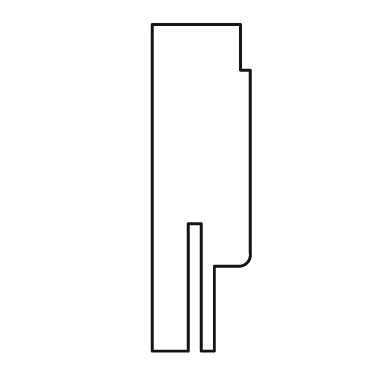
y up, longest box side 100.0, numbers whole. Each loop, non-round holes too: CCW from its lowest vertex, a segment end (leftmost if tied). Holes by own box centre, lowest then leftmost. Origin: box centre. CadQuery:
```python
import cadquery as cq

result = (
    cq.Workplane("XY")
    .moveTo(-15.0, -50.0)
    .lineTo(-4.0, -50.0)
    .lineTo(-4.0, -11.0)
    .lineTo(0.0, -11.0)
    .lineTo(0.0, -50.0)
    .lineTo(4.0, -50.0)
    .lineTo(4.0, -24.0)
    .lineTo(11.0, -24.0)
    .threePointArc((14.0, -23.0), (15.0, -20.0))
    .lineTo(15.0, 36.0)
    .lineTo(12.0, 36.0)
    .lineTo(12.0, 50.0)
    .lineTo(-15.0, 50.0)
    .close()
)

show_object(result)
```